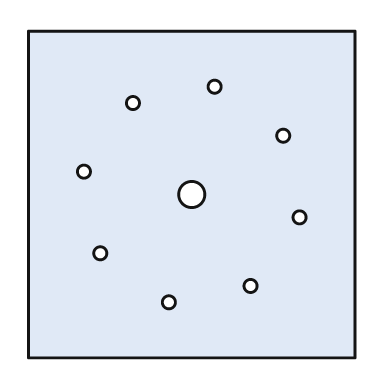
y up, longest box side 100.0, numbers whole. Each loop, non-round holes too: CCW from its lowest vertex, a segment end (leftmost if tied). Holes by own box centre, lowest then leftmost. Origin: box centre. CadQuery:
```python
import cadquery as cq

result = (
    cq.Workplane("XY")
    .moveTo(-50.0, -50.0)
    .lineTo(50.0, -50.0)
    .lineTo(50.0, 50.0)
    .lineTo(-50.0, 50.0)
    .close()
    .moveTo(-7.0, -33.0)
    .circle(2.0)
    .moveTo(18.0, -28.0)
    .circle(2.0)
    .moveTo(-28.0, -18.0)
    .circle(2.0)
    .moveTo(33.0, -7.0)
    .circle(2.0)
    .moveTo(0.0, 0.0)
    .circle(4.0)
    .moveTo(-33.0, 7.0)
    .circle(2.0)
    .moveTo(28.0, 18.0)
    .circle(2.0)
    .moveTo(-18.0, 28.0)
    .circle(2.0)
    .moveTo(7.0, 33.0)
    .circle(2.0)
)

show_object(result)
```